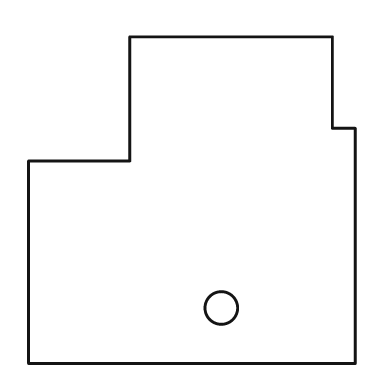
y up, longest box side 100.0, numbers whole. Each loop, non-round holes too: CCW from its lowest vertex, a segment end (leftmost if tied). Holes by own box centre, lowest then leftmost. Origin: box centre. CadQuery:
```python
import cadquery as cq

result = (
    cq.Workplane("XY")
    .moveTo(-50.0, -50.0)
    .lineTo(50.0, -50.0)
    .lineTo(50.0, 22.0)
    .lineTo(43.0, 22.0)
    .lineTo(43.0, 50.0)
    .lineTo(-19.0, 50.0)
    .lineTo(-19.0, 12.0)
    .lineTo(-50.0, 12.0)
    .close()
    .moveTo(9.0, -33.0)
    .circle(5.0)
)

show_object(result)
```